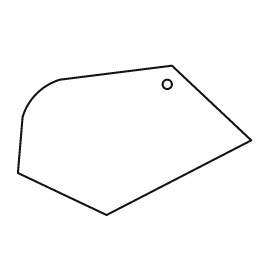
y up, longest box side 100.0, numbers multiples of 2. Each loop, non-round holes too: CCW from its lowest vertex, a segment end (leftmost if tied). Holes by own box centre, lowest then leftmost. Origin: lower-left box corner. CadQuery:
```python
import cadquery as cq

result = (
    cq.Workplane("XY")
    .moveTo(38.0, 0.0)
    .lineTo(100.0, 32.0)
    .lineTo(66.0, 64.0)
    .lineTo(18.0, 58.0)
    .threePointArc((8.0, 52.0), (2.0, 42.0))
    .lineTo(0.0, 18.0)
    .close()
    .moveTo(64.0, 56.0)
    .circle(2.0)
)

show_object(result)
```